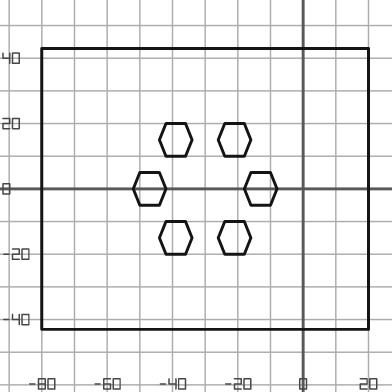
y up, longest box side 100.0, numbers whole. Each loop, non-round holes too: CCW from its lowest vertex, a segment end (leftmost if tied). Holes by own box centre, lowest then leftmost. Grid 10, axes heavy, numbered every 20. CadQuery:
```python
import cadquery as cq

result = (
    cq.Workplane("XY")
    .moveTo(-80.0, -43.0)
    .lineTo(20.0, -43.0)
    .lineTo(20.0, 43.0)
    .lineTo(-80.0, 43.0)
    .close()
    .moveTo(-42.0, -20.0)
    .lineTo(-36.0, -20.0)
    .lineTo(-34.0, -15.0)
    .lineTo(-36.0, -10.0)
    .lineTo(-42.0, -10.0)
    .lineTo(-44.0, -15.0)
    .close()
    .moveTo(-24.0, -20.0)
    .lineTo(-18.0, -20.0)
    .lineTo(-16.0, -15.0)
    .lineTo(-18.0, -10.0)
    .lineTo(-24.0, -10.0)
    .lineTo(-26.0, -15.0)
    .close()
    .moveTo(-50.0, -5.0)
    .lineTo(-44.0, -5.0)
    .lineTo(-42.0, 0.0)
    .lineTo(-44.0, 5.0)
    .lineTo(-50.0, 5.0)
    .lineTo(-52.0, 0.0)
    .close()
    .moveTo(-16.0, -5.0)
    .lineTo(-10.0, -5.0)
    .lineTo(-8.0, 0.0)
    .lineTo(-10.0, 5.0)
    .lineTo(-16.0, 5.0)
    .lineTo(-18.0, 0.0)
    .close()
    .moveTo(-42.0, 10.0)
    .lineTo(-36.0, 10.0)
    .lineTo(-34.0, 15.0)
    .lineTo(-36.0, 20.0)
    .lineTo(-42.0, 20.0)
    .lineTo(-44.0, 15.0)
    .close()
    .moveTo(-24.0, 10.0)
    .lineTo(-18.0, 10.0)
    .lineTo(-16.0, 15.0)
    .lineTo(-18.0, 20.0)
    .lineTo(-24.0, 20.0)
    .lineTo(-26.0, 15.0)
    .close()
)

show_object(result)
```